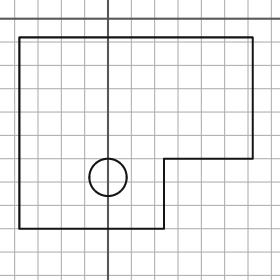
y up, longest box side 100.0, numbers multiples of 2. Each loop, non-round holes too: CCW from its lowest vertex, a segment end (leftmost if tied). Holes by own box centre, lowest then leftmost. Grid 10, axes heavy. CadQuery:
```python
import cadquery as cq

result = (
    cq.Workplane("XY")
    .moveTo(-38.0, -90.0)
    .lineTo(24.0, -90.0)
    .lineTo(24.0, -60.0)
    .lineTo(62.0, -60.0)
    .lineTo(62.0, -8.0)
    .lineTo(-38.0, -8.0)
    .close()
    .moveTo(0.0, -68.0)
    .circle(8.0)
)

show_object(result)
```